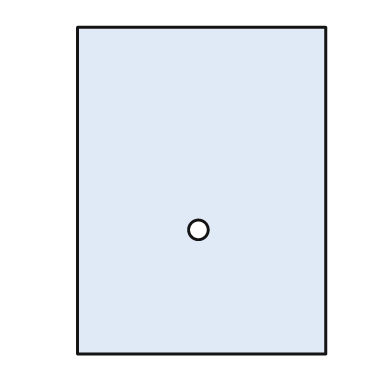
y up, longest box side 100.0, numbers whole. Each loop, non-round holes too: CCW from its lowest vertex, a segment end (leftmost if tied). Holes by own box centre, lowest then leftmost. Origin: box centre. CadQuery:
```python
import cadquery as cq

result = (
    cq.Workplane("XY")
    .moveTo(-38.0, -50.0)
    .lineTo(38.0, -50.0)
    .lineTo(38.0, 50.0)
    .lineTo(-38.0, 50.0)
    .close()
    .moveTo(-1.0, -12.0)
    .circle(3.0)
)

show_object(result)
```